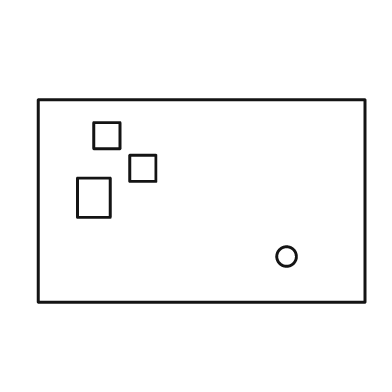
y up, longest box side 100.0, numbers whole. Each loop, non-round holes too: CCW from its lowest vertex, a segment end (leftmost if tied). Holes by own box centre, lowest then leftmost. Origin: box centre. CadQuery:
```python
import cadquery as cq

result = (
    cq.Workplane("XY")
    .moveTo(-50.0, -31.0)
    .lineTo(50.0, -31.0)
    .lineTo(50.0, 31.0)
    .lineTo(-50.0, 31.0)
    .close()
    .moveTo(26.0, -17.0)
    .circle(3.0)
    .moveTo(-38.0, -5.0)
    .lineTo(-28.0, -5.0)
    .lineTo(-28.0, 7.0)
    .lineTo(-38.0, 7.0)
    .close()
    .moveTo(-22.0, 6.0)
    .lineTo(-14.0, 6.0)
    .lineTo(-14.0, 14.0)
    .lineTo(-22.0, 14.0)
    .close()
    .moveTo(-33.0, 16.0)
    .lineTo(-25.0, 16.0)
    .lineTo(-25.0, 24.0)
    .lineTo(-33.0, 24.0)
    .close()
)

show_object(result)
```